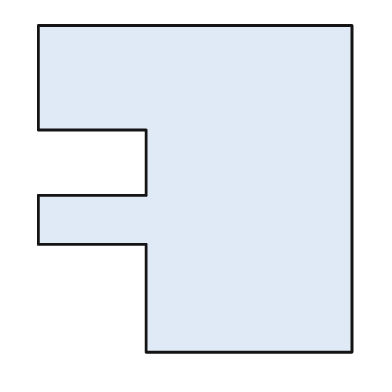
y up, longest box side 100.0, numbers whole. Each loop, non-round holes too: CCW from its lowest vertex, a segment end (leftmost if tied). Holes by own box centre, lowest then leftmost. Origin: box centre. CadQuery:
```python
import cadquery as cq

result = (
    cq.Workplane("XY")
    .moveTo(-15.0, -50.0)
    .lineTo(48.0, -50.0)
    .lineTo(48.0, 50.0)
    .lineTo(-48.0, 50.0)
    .lineTo(-48.0, 18.0)
    .lineTo(-15.0, 18.0)
    .lineTo(-15.0, -2.0)
    .lineTo(-48.0, -2.0)
    .lineTo(-48.0, -17.0)
    .lineTo(-15.0, -17.0)
    .close()
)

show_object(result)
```